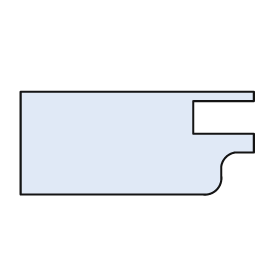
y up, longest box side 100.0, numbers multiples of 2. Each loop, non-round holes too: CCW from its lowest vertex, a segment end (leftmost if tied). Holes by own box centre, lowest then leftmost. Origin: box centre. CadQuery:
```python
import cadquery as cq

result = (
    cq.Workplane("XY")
    .moveTo(-50.0, -22.0)
    .lineTo(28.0, -22.0)
    .threePointArc((34.0, -20.0), (36.0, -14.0))
    .lineTo(36.0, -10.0)
    .threePointArc((38.0, -6.0), (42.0, -4.0))
    .lineTo(50.0, -4.0)
    .lineTo(50.0, 4.0)
    .lineTo(24.0, 4.0)
    .lineTo(24.0, 18.0)
    .lineTo(50.0, 18.0)
    .lineTo(50.0, 22.0)
    .lineTo(-50.0, 22.0)
    .close()
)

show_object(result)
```